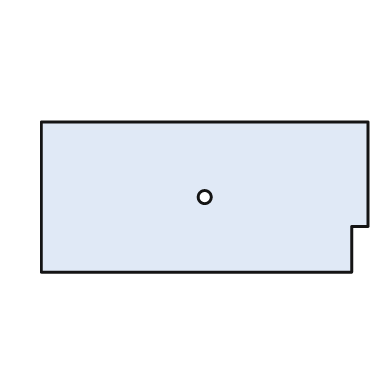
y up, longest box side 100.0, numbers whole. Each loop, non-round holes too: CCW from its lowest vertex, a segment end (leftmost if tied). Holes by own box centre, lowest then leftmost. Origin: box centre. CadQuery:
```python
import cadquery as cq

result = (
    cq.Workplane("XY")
    .moveTo(-50.0, -23.0)
    .lineTo(45.0, -23.0)
    .lineTo(45.0, -9.0)
    .lineTo(50.0, -9.0)
    .lineTo(50.0, 23.0)
    .lineTo(-50.0, 23.0)
    .close()
    .moveTo(0.0, 0.0)
    .circle(2.0)
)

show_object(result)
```